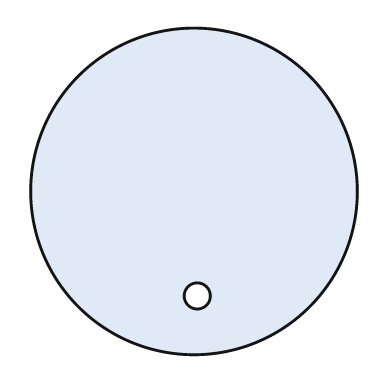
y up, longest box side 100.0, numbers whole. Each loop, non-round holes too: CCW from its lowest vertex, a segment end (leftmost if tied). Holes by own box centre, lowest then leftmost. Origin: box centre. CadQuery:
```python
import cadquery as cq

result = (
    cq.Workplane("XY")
    .moveTo(0.0, 0.0)
    .circle(50.0)
    .moveTo(1.0, -32.0)
    .circle(4.0)
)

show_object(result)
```